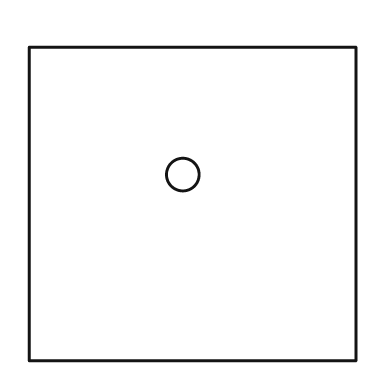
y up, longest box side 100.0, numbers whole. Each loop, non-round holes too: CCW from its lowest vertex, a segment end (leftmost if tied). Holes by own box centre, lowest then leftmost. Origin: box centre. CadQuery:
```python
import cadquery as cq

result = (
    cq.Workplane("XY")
    .moveTo(-50.0, -48.0)
    .lineTo(50.0, -48.0)
    .lineTo(50.0, 48.0)
    .lineTo(-50.0, 48.0)
    .close()
    .moveTo(-3.0, 9.0)
    .circle(5.0)
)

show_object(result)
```